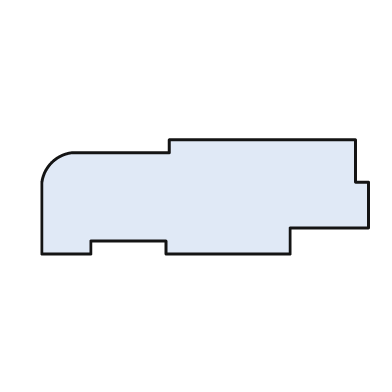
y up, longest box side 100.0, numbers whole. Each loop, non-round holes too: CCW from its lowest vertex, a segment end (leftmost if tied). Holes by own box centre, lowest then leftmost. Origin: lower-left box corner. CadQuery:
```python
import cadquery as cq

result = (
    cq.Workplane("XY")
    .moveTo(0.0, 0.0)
    .lineTo(15.0, 0.0)
    .lineTo(15.0, 4.0)
    .lineTo(38.0, 4.0)
    .lineTo(38.0, 0.0)
    .lineTo(76.0, 0.0)
    .lineTo(76.0, 8.0)
    .lineTo(100.0, 8.0)
    .lineTo(100.0, 22.0)
    .lineTo(96.0, 22.0)
    .lineTo(96.0, 35.0)
    .lineTo(39.0, 35.0)
    .lineTo(39.0, 31.0)
    .lineTo(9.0, 31.0)
    .threePointArc((3.0, 28.0), (0.0, 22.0))
    .close()
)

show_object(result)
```